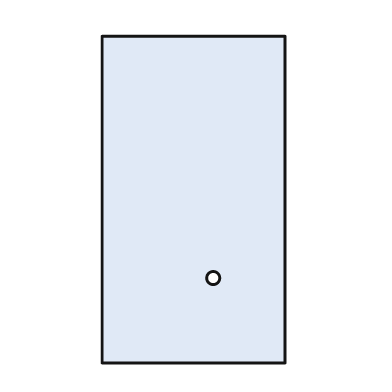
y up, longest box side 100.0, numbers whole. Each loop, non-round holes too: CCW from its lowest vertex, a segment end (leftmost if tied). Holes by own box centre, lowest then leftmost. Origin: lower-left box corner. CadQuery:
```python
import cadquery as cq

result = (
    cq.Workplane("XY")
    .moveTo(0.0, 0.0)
    .lineTo(56.0, 0.0)
    .lineTo(56.0, 100.0)
    .lineTo(0.0, 100.0)
    .close()
    .moveTo(34.0, 26.0)
    .circle(2.0)
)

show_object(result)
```